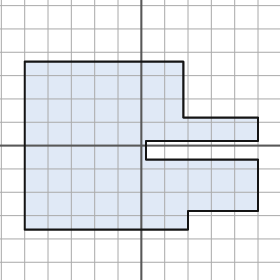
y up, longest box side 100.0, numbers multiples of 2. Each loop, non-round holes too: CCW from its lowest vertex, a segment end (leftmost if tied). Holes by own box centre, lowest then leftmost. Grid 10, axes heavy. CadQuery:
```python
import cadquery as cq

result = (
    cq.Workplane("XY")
    .moveTo(-50.0, -36.0)
    .lineTo(20.0, -36.0)
    .lineTo(20.0, -28.0)
    .lineTo(50.0, -28.0)
    .lineTo(50.0, -6.0)
    .lineTo(2.0, -6.0)
    .lineTo(2.0, 2.0)
    .lineTo(50.0, 2.0)
    .lineTo(50.0, 12.0)
    .lineTo(18.0, 12.0)
    .lineTo(18.0, 36.0)
    .lineTo(-50.0, 36.0)
    .close()
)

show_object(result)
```